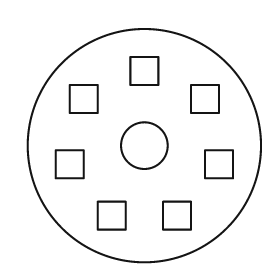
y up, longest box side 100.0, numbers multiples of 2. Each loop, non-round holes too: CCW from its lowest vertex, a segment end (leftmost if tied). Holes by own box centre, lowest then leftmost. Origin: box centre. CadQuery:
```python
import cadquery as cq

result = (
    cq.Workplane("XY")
    .moveTo(0.0, 0.0)
    .circle(50.0)
    .moveTo(-20.0, -36.0)
    .lineTo(-8.0, -36.0)
    .lineTo(-8.0, -24.0)
    .lineTo(-20.0, -24.0)
    .close()
    .moveTo(8.0, -36.0)
    .lineTo(20.0, -36.0)
    .lineTo(20.0, -24.0)
    .lineTo(8.0, -24.0)
    .close()
    .moveTo(-38.0, -14.0)
    .lineTo(-26.0, -14.0)
    .lineTo(-26.0, -2.0)
    .lineTo(-38.0, -2.0)
    .close()
    .moveTo(26.0, -14.0)
    .lineTo(38.0, -14.0)
    .lineTo(38.0, -2.0)
    .lineTo(26.0, -2.0)
    .close()
    .moveTo(0.0, 0.0)
    .circle(10.0)
    .moveTo(-32.0, 14.0)
    .lineTo(-20.0, 14.0)
    .lineTo(-20.0, 26.0)
    .lineTo(-32.0, 26.0)
    .close()
    .moveTo(20.0, 14.0)
    .lineTo(32.0, 14.0)
    .lineTo(32.0, 26.0)
    .lineTo(20.0, 26.0)
    .close()
    .moveTo(-6.0, 26.0)
    .lineTo(6.0, 26.0)
    .lineTo(6.0, 38.0)
    .lineTo(-6.0, 38.0)
    .close()
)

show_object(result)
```